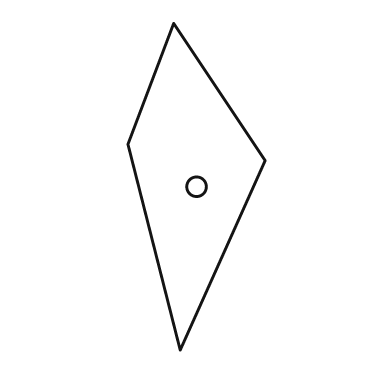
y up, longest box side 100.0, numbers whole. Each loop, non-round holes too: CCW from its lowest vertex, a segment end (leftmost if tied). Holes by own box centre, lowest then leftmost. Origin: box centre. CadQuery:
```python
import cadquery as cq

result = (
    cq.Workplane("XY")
    .moveTo(-5.0, -50.0)
    .lineTo(21.0, 8.0)
    .lineTo(-7.0, 50.0)
    .lineTo(-21.0, 13.0)
    .close()
    .moveTo(0.0, 0.0)
    .circle(3.0)
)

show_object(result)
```